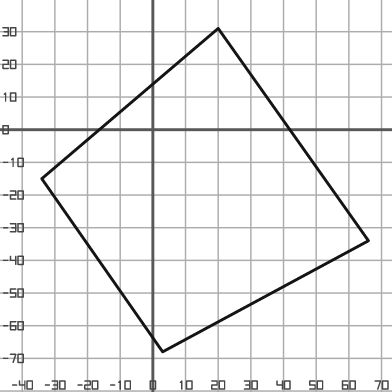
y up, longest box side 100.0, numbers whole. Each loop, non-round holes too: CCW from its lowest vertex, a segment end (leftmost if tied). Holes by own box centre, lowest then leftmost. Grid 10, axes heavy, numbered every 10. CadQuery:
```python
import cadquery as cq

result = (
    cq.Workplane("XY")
    .moveTo(3.0, -68.0)
    .lineTo(66.0, -34.0)
    .lineTo(20.0, 31.0)
    .lineTo(-34.0, -15.0)
    .close()
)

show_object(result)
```